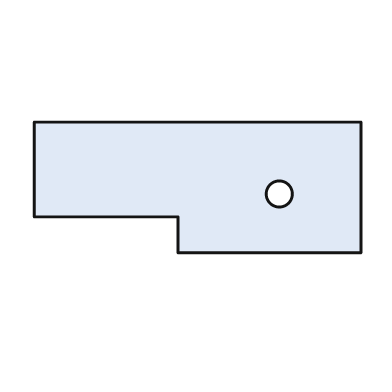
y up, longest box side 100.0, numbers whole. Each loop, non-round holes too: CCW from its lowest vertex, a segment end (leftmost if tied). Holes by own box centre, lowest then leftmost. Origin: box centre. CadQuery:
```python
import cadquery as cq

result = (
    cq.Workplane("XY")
    .moveTo(-6.0, -20.0)
    .lineTo(50.0, -20.0)
    .lineTo(50.0, 20.0)
    .lineTo(-50.0, 20.0)
    .lineTo(-50.0, -9.0)
    .lineTo(-6.0, -9.0)
    .close()
    .moveTo(25.0, -2.0)
    .circle(4.0)
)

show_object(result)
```